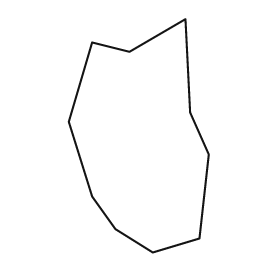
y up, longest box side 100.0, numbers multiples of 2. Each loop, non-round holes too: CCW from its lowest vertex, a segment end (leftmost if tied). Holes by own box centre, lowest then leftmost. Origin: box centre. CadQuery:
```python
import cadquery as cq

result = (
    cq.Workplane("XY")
    .moveTo(6.0, -50.0)
    .lineTo(26.0, -44.0)
    .lineTo(30.0, -8.0)
    .lineTo(22.0, 10.0)
    .lineTo(20.0, 50.0)
    .lineTo(-4.0, 36.0)
    .lineTo(-20.0, 40.0)
    .lineTo(-30.0, 6.0)
    .lineTo(-20.0, -26.0)
    .lineTo(-10.0, -40.0)
    .close()
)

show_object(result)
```